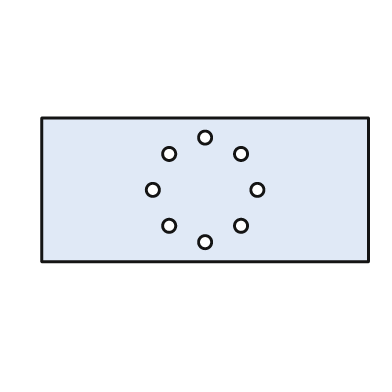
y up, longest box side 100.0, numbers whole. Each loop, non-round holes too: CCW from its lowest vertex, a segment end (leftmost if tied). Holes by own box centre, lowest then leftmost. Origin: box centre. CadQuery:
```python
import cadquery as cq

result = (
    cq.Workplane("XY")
    .moveTo(-50.0, -22.0)
    .lineTo(50.0, -22.0)
    .lineTo(50.0, 22.0)
    .lineTo(-50.0, 22.0)
    .close()
    .moveTo(0.0, -16.0)
    .circle(2.0)
    .moveTo(-11.0, -11.0)
    .circle(2.0)
    .moveTo(11.0, -11.0)
    .circle(2.0)
    .moveTo(-16.0, 0.0)
    .circle(2.0)
    .moveTo(16.0, 0.0)
    .circle(2.0)
    .moveTo(-11.0, 11.0)
    .circle(2.0)
    .moveTo(11.0, 11.0)
    .circle(2.0)
    .moveTo(0.0, 16.0)
    .circle(2.0)
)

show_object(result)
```